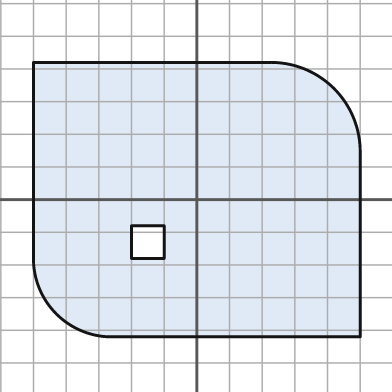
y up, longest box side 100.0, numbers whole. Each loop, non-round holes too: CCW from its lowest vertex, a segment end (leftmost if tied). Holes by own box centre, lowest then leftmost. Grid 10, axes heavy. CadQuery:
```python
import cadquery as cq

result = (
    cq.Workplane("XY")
    .moveTo(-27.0, -42.0)
    .lineTo(50.0, -42.0)
    .lineTo(50.0, 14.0)
    .threePointArc((42.0, 34.0), (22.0, 42.0))
    .lineTo(-50.0, 42.0)
    .lineTo(-50.0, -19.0)
    .threePointArc((-43.0, -35.0), (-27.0, -42.0))
    .close()
    .moveTo(-20.0, -18.0)
    .lineTo(-10.0, -18.0)
    .lineTo(-10.0, -8.0)
    .lineTo(-20.0, -8.0)
    .close()
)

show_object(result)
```